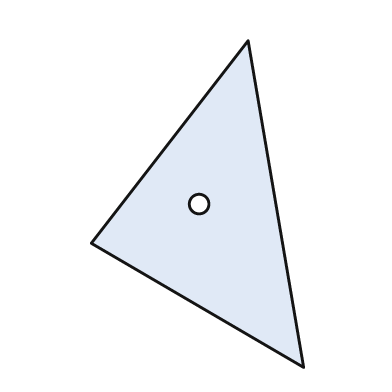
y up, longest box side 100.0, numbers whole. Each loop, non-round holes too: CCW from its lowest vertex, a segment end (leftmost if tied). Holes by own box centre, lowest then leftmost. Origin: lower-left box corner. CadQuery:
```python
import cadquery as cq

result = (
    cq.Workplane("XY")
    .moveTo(65.0, 0.0)
    .lineTo(48.0, 100.0)
    .lineTo(0.0, 38.0)
    .close()
    .moveTo(33.0, 50.0)
    .circle(3.0)
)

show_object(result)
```